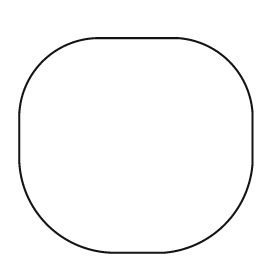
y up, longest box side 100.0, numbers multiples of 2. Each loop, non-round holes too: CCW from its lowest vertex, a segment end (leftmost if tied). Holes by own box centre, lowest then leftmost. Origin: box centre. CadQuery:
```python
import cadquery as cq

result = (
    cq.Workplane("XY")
    .moveTo(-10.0, -46.0)
    .lineTo(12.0, -46.0)
    .threePointArc((38.0, -34.0), (50.0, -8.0))
    .lineTo(50.0, 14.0)
    .threePointArc((40.0, 36.0), (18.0, 46.0))
    .lineTo(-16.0, 46.0)
    .threePointArc((-40.0, 36.0), (-50.0, 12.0))
    .lineTo(-50.0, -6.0)
    .threePointArc((-38.0, -34.0), (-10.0, -46.0))
    .close()
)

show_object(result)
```